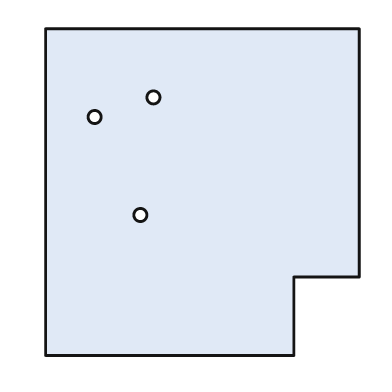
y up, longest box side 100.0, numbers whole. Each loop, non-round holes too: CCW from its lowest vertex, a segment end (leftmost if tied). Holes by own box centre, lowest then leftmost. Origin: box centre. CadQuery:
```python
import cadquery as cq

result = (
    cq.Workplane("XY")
    .moveTo(-48.0, -50.0)
    .lineTo(28.0, -50.0)
    .lineTo(28.0, -26.0)
    .lineTo(48.0, -26.0)
    .lineTo(48.0, 50.0)
    .lineTo(-48.0, 50.0)
    .close()
    .moveTo(-19.0, -7.0)
    .circle(2.0)
    .moveTo(-33.0, 23.0)
    .circle(2.0)
    .moveTo(-15.0, 29.0)
    .circle(2.0)
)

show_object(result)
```